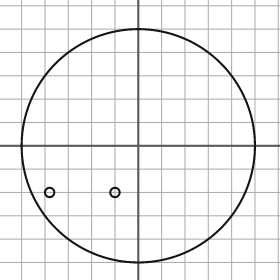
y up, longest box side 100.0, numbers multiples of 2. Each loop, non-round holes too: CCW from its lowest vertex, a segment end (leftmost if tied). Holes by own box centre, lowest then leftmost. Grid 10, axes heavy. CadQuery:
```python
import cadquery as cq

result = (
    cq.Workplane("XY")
    .moveTo(0.0, 0.0)
    .circle(50.0)
    .moveTo(-38.0, -20.0)
    .circle(2.0)
    .moveTo(-10.0, -20.0)
    .circle(2.0)
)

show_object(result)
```